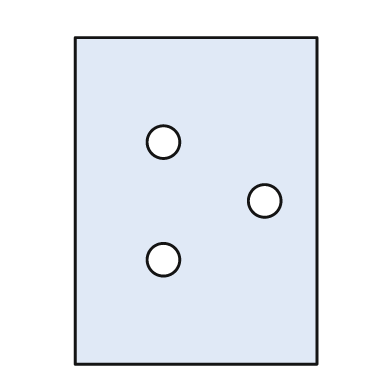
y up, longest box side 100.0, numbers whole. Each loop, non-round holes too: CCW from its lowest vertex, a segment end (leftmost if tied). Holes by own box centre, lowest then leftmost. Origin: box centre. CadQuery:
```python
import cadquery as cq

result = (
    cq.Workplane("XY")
    .moveTo(-37.0, -50.0)
    .lineTo(37.0, -50.0)
    .lineTo(37.0, 50.0)
    .lineTo(-37.0, 50.0)
    .close()
    .moveTo(-10.0, -18.0)
    .circle(5.0)
    .moveTo(21.0, 0.0)
    .circle(5.0)
    .moveTo(-10.0, 18.0)
    .circle(5.0)
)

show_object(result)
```